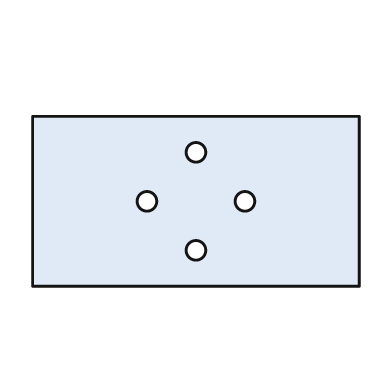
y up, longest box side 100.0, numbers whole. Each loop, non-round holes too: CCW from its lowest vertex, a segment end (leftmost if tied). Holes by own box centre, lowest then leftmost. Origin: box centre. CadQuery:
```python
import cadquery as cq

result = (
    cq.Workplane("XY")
    .moveTo(-50.0, -26.0)
    .lineTo(50.0, -26.0)
    .lineTo(50.0, 26.0)
    .lineTo(-50.0, 26.0)
    .close()
    .moveTo(0.0, -15.0)
    .circle(3.0)
    .moveTo(-15.0, 0.0)
    .circle(3.0)
    .moveTo(15.0, 0.0)
    .circle(3.0)
    .moveTo(0.0, 15.0)
    .circle(3.0)
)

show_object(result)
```